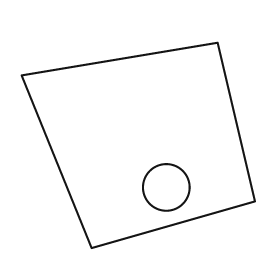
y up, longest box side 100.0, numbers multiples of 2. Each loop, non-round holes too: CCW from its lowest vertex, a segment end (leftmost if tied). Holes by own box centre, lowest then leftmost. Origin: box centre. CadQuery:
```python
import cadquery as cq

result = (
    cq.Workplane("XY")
    .moveTo(-20.0, -44.0)
    .lineTo(50.0, -24.0)
    .lineTo(34.0, 44.0)
    .lineTo(-50.0, 30.0)
    .close()
    .moveTo(12.0, -18.0)
    .circle(10.0)
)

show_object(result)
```